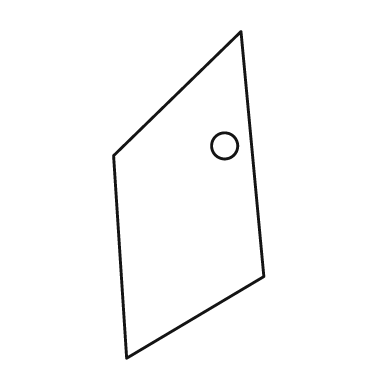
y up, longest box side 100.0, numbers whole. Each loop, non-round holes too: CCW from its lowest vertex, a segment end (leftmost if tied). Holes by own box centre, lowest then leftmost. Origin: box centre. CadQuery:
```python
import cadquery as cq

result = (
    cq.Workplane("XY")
    .moveTo(-19.0, -50.0)
    .lineTo(23.0, -25.0)
    .lineTo(16.0, 50.0)
    .lineTo(-23.0, 12.0)
    .close()
    .moveTo(11.0, 15.0)
    .circle(4.0)
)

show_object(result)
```